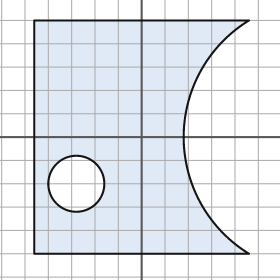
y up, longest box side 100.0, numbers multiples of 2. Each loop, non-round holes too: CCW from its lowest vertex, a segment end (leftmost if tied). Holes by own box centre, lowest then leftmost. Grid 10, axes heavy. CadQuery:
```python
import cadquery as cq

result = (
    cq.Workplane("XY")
    .moveTo(-46.0, -50.0)
    .lineTo(46.0, -50.0)
    .threePointArc((18.0, 0.0), (46.0, 50.0))
    .lineTo(-46.0, 50.0)
    .close()
    .moveTo(-28.0, -20.0)
    .circle(12.0)
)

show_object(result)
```